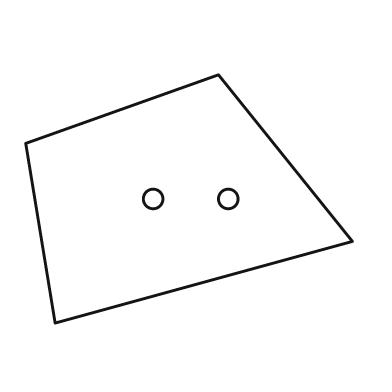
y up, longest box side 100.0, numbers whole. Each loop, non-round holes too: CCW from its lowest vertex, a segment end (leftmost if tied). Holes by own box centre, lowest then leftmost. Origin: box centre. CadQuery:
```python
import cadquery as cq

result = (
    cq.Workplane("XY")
    .moveTo(-41.0, -38.0)
    .lineTo(50.0, -13.0)
    .lineTo(9.0, 38.0)
    .lineTo(-50.0, 17.0)
    .close()
    .moveTo(-11.0, 0.0)
    .circle(3.0)
    .moveTo(12.0, 0.0)
    .circle(3.0)
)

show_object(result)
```